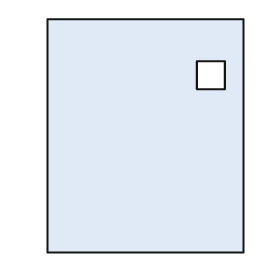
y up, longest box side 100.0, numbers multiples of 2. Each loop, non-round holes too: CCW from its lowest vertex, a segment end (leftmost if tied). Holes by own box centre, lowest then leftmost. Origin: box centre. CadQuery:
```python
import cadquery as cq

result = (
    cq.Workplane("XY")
    .moveTo(-42.0, -50.0)
    .lineTo(42.0, -50.0)
    .lineTo(42.0, 50.0)
    .lineTo(-42.0, 50.0)
    .close()
    .moveTo(22.0, 20.0)
    .lineTo(34.0, 20.0)
    .lineTo(34.0, 32.0)
    .lineTo(22.0, 32.0)
    .close()
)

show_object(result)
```